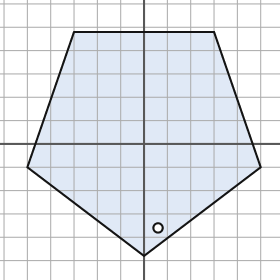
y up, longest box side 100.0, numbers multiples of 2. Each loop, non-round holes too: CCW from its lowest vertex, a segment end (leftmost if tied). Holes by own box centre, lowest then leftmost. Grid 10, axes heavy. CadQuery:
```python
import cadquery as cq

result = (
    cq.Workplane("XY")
    .moveTo(0.0, -48.0)
    .lineTo(50.0, -10.0)
    .lineTo(30.0, 48.0)
    .lineTo(-30.0, 48.0)
    .lineTo(-50.0, -10.0)
    .close()
    .moveTo(6.0, -36.0)
    .circle(2.0)
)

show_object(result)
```